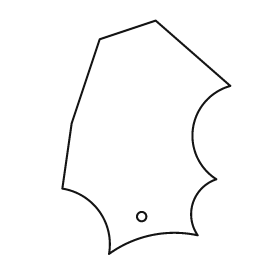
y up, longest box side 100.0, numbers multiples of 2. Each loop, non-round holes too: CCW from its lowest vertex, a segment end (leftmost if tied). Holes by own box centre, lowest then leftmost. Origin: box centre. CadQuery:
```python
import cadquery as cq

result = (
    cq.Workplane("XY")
    .moveTo(-16.0, -50.0)
    .threePointArc((2.0, -42.0), (22.0, -42.0))
    .threePointArc((20.0, -28.0), (30.0, -18.0))
    .threePointArc((20.0, 4.0), (36.0, 22.0))
    .lineTo(4.0, 50.0)
    .lineTo(-20.0, 42.0)
    .lineTo(-32.0, 6.0)
    .lineTo(-36.0, -22.0)
    .threePointArc((-20.0, -32.0), (-16.0, -50.0))
    .close()
    .moveTo(-2.0, -34.0)
    .circle(2.0)
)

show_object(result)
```